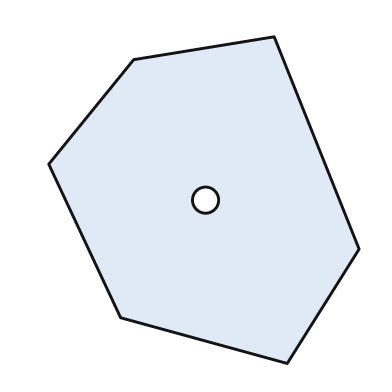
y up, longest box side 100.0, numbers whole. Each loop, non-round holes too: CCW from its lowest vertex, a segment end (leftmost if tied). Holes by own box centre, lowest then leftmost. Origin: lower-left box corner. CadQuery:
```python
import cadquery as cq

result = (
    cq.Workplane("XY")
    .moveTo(73.0, 0.0)
    .lineTo(95.0, 35.0)
    .lineTo(69.0, 100.0)
    .lineTo(26.0, 93.0)
    .lineTo(0.0, 61.0)
    .lineTo(22.0, 14.0)
    .close()
    .moveTo(48.0, 50.0)
    .circle(4.0)
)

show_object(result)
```